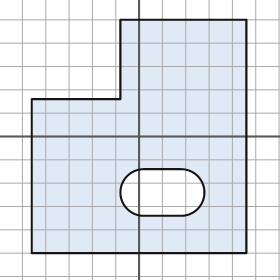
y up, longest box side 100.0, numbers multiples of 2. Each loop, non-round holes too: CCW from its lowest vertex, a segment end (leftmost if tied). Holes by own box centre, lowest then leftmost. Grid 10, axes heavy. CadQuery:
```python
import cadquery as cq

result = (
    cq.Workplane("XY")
    .moveTo(-46.0, -50.0)
    .lineTo(46.0, -50.0)
    .lineTo(46.0, 50.0)
    .lineTo(-8.0, 50.0)
    .lineTo(-8.0, 16.0)
    .lineTo(-46.0, 16.0)
    .close()
    .moveTo(2.0, -34.0)
    .lineTo(18.0, -34.0)
    .threePointArc((28.0, -24.0), (18.0, -14.0))
    .lineTo(2.0, -14.0)
    .threePointArc((-8.0, -24.0), (2.0, -34.0))
    .close()
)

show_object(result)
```